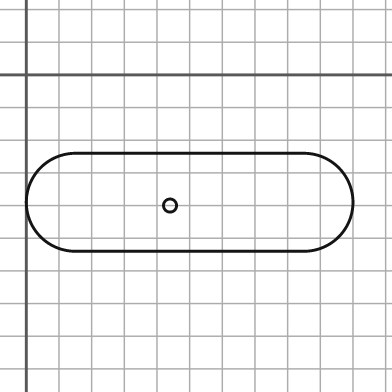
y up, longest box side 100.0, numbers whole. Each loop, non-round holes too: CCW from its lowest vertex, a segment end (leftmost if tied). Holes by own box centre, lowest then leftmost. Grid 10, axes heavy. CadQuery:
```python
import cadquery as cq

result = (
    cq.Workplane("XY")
    .moveTo(15.0, -54.0)
    .lineTo(85.0, -54.0)
    .threePointArc((100.0, -39.0), (85.0, -24.0))
    .lineTo(15.0, -24.0)
    .threePointArc((0.0, -39.0), (15.0, -54.0))
    .close()
    .moveTo(44.0, -40.0)
    .circle(2.0)
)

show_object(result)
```